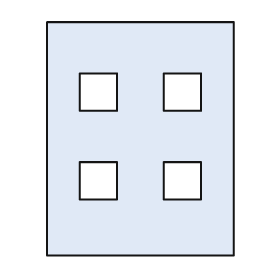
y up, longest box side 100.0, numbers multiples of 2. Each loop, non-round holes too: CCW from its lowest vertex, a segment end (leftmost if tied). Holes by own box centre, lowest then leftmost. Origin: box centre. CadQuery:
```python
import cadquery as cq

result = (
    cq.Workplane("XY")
    .moveTo(-40.0, -50.0)
    .lineTo(40.0, -50.0)
    .lineTo(40.0, 50.0)
    .lineTo(-40.0, 50.0)
    .close()
    .moveTo(-26.0, -26.0)
    .lineTo(-10.0, -26.0)
    .lineTo(-10.0, -10.0)
    .lineTo(-26.0, -10.0)
    .close()
    .moveTo(10.0, -26.0)
    .lineTo(26.0, -26.0)
    .lineTo(26.0, -10.0)
    .lineTo(10.0, -10.0)
    .close()
    .moveTo(-26.0, 12.0)
    .lineTo(-10.0, 12.0)
    .lineTo(-10.0, 28.0)
    .lineTo(-26.0, 28.0)
    .close()
    .moveTo(10.0, 12.0)
    .lineTo(26.0, 12.0)
    .lineTo(26.0, 28.0)
    .lineTo(10.0, 28.0)
    .close()
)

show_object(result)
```